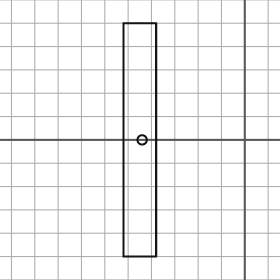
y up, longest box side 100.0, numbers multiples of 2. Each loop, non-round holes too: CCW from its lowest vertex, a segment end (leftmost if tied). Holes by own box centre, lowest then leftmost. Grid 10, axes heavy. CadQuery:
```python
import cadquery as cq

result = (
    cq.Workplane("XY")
    .moveTo(-52.0, -50.0)
    .lineTo(-38.0, -50.0)
    .lineTo(-38.0, 50.0)
    .lineTo(-52.0, 50.0)
    .close()
    .moveTo(-44.0, 0.0)
    .circle(2.0)
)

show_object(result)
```